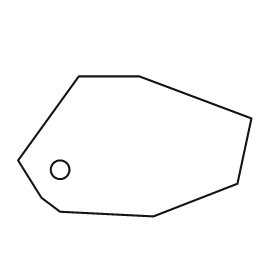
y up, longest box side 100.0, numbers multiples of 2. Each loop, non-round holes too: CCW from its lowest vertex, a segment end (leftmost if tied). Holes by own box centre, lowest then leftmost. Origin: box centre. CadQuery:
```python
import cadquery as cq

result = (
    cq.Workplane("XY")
    .moveTo(8.0, -30.0)
    .lineTo(44.0, -16.0)
    .lineTo(50.0, 12.0)
    .lineTo(2.0, 30.0)
    .lineTo(-24.0, 30.0)
    .lineTo(-50.0, -6.0)
    .lineTo(-40.0, -22.0)
    .lineTo(-32.0, -28.0)
    .close()
    .moveTo(-32.0, -10.0)
    .circle(4.0)
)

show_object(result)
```